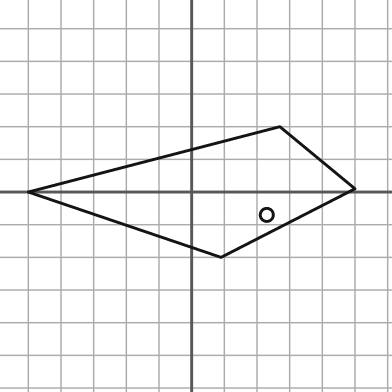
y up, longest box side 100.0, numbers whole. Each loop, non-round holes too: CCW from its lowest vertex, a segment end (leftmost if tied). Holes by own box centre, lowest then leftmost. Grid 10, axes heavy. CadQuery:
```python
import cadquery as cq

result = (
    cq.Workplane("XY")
    .moveTo(9.0, -20.0)
    .lineTo(50.0, 1.0)
    .lineTo(27.0, 20.0)
    .lineTo(-50.0, 0.0)
    .close()
    .moveTo(23.0, -7.0)
    .circle(2.0)
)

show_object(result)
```